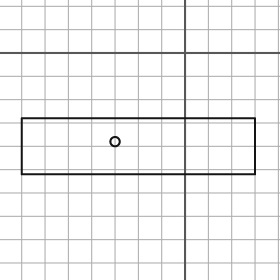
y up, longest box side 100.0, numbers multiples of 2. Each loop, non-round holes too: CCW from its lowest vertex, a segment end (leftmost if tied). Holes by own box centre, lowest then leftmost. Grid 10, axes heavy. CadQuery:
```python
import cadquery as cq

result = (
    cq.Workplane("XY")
    .moveTo(-70.0, -52.0)
    .lineTo(30.0, -52.0)
    .lineTo(30.0, -28.0)
    .lineTo(-70.0, -28.0)
    .close()
    .moveTo(-30.0, -38.0)
    .circle(2.0)
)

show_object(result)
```